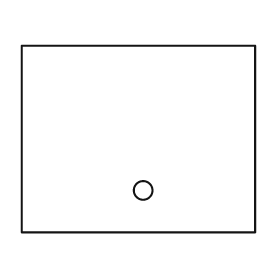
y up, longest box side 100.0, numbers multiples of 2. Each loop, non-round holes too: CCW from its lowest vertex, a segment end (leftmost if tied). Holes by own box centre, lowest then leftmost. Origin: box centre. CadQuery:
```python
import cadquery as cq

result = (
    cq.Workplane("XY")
    .moveTo(-50.0, -40.0)
    .lineTo(50.0, -40.0)
    .lineTo(50.0, 40.0)
    .lineTo(-50.0, 40.0)
    .close()
    .moveTo(2.0, -22.0)
    .circle(4.0)
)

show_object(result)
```